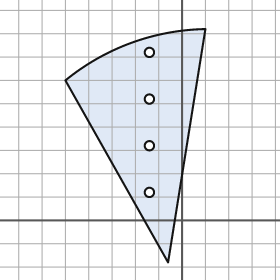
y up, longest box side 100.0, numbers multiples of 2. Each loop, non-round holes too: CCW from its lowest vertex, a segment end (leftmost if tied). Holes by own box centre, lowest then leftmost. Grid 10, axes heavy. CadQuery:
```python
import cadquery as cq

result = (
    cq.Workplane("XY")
    .moveTo(-6.0, -18.0)
    .lineTo(10.0, 82.0)
    .threePointArc((-22.0, 76.0), (-50.0, 60.0))
    .close()
    .moveTo(-14.0, 12.0)
    .circle(2.0)
    .moveTo(-14.0, 32.0)
    .circle(2.0)
    .moveTo(-14.0, 52.0)
    .circle(2.0)
    .moveTo(-14.0, 72.0)
    .circle(2.0)
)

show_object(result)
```